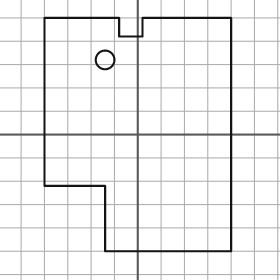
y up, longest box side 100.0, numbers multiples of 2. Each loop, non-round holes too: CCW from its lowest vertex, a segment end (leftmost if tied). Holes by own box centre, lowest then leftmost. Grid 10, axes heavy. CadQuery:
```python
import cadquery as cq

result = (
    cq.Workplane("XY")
    .moveTo(-14.0, -50.0)
    .lineTo(40.0, -50.0)
    .lineTo(40.0, 50.0)
    .lineTo(2.0, 50.0)
    .lineTo(2.0, 42.0)
    .lineTo(-8.0, 42.0)
    .lineTo(-8.0, 50.0)
    .lineTo(-40.0, 50.0)
    .lineTo(-40.0, -22.0)
    .lineTo(-14.0, -22.0)
    .close()
    .moveTo(-14.0, 32.0)
    .circle(4.0)
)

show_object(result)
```